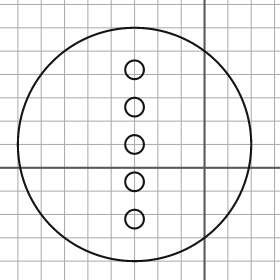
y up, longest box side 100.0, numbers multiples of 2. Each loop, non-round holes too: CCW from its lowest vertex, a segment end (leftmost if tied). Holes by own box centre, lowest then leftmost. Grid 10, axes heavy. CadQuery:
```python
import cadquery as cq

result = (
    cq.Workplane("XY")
    .moveTo(-30.0, 10.0)
    .circle(50.0)
    .moveTo(-30.0, -22.0)
    .circle(4.0)
    .moveTo(-30.0, -6.0)
    .circle(4.0)
    .moveTo(-30.0, 10.0)
    .circle(4.0)
    .moveTo(-30.0, 26.0)
    .circle(4.0)
    .moveTo(-30.0, 42.0)
    .circle(4.0)
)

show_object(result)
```